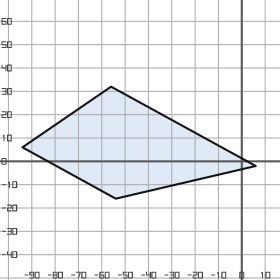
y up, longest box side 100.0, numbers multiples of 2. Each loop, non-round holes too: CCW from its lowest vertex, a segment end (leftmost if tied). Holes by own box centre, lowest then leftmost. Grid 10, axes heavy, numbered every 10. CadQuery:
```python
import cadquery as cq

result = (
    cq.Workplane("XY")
    .moveTo(-54.0, -16.0)
    .lineTo(6.0, -2.0)
    .lineTo(-56.0, 32.0)
    .lineTo(-94.0, 6.0)
    .close()
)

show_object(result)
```